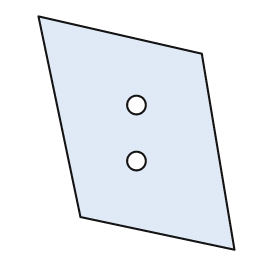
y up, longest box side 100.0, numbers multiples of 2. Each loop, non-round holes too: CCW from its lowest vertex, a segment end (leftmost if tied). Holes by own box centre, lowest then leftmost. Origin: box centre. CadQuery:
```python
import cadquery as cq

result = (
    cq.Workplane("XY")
    .moveTo(42.0, -50.0)
    .lineTo(28.0, 34.0)
    .lineTo(-42.0, 50.0)
    .lineTo(-24.0, -36.0)
    .close()
    .moveTo(0.0, -12.0)
    .circle(4.0)
    .moveTo(0.0, 12.0)
    .circle(4.0)
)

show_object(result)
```